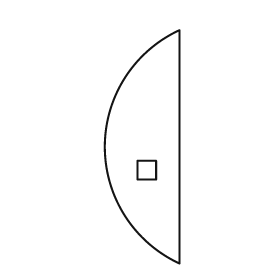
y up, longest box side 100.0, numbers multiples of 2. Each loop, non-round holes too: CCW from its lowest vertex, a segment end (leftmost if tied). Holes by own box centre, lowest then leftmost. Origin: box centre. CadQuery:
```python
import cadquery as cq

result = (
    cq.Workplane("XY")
    .moveTo(16.0, -50.0)
    .lineTo(16.0, 50.0)
    .threePointArc((-16.0, 0.0), (16.0, -50.0))
    .close()
    .moveTo(-2.0, -14.0)
    .lineTo(6.0, -14.0)
    .lineTo(6.0, -6.0)
    .lineTo(-2.0, -6.0)
    .close()
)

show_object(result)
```